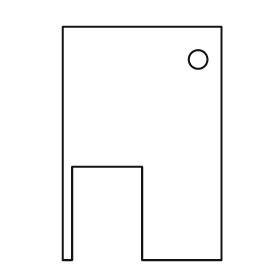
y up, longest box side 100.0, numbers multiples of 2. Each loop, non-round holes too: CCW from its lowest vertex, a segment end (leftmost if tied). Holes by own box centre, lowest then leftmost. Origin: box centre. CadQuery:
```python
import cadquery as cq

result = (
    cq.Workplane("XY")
    .moveTo(-34.0, -50.0)
    .lineTo(-30.0, -50.0)
    .lineTo(-30.0, -10.0)
    .lineTo(0.0, -10.0)
    .lineTo(0.0, -50.0)
    .lineTo(34.0, -50.0)
    .lineTo(34.0, 50.0)
    .lineTo(-34.0, 50.0)
    .close()
    .moveTo(24.0, 36.0)
    .circle(4.0)
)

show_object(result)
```